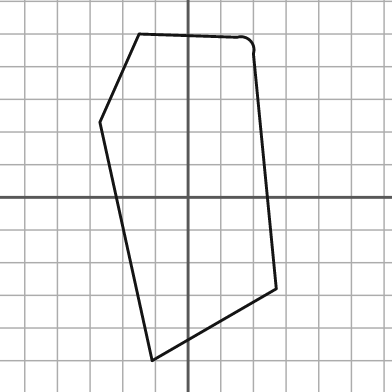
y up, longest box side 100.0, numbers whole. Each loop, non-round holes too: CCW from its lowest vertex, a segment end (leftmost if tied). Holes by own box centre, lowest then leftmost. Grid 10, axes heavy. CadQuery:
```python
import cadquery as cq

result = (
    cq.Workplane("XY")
    .moveTo(-11.0, -50.0)
    .lineTo(27.0, -28.0)
    .lineTo(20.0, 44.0)
    .threePointArc((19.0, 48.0), (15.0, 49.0))
    .lineTo(-15.0, 50.0)
    .lineTo(-27.0, 23.0)
    .close()
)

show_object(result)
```